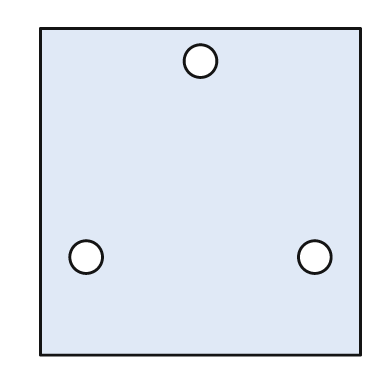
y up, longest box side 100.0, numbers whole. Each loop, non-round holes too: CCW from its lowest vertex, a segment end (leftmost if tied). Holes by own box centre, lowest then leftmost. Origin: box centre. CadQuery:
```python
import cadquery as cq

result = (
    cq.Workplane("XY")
    .moveTo(-49.0, -50.0)
    .lineTo(49.0, -50.0)
    .lineTo(49.0, 50.0)
    .lineTo(-49.0, 50.0)
    .close()
    .moveTo(-35.0, -20.0)
    .circle(5.0)
    .moveTo(35.0, -20.0)
    .circle(5.0)
    .moveTo(0.0, 40.0)
    .circle(5.0)
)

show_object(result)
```